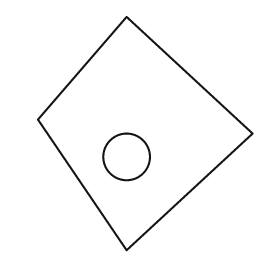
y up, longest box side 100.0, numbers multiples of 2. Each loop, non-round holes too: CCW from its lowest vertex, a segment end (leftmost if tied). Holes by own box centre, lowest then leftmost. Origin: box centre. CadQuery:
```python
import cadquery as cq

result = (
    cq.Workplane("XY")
    .moveTo(-8.0, -50.0)
    .lineTo(46.0, 0.0)
    .lineTo(-8.0, 50.0)
    .lineTo(-46.0, 6.0)
    .close()
    .moveTo(-8.0, -10.0)
    .circle(10.0)
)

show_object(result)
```